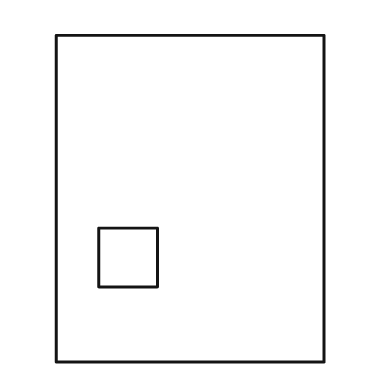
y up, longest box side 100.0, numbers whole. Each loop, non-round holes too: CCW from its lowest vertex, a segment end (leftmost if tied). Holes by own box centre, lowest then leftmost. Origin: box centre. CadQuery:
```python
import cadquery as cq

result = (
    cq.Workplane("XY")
    .moveTo(-41.0, -50.0)
    .lineTo(41.0, -50.0)
    .lineTo(41.0, 50.0)
    .lineTo(-41.0, 50.0)
    .close()
    .moveTo(-28.0, -27.0)
    .lineTo(-10.0, -27.0)
    .lineTo(-10.0, -9.0)
    .lineTo(-28.0, -9.0)
    .close()
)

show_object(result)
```